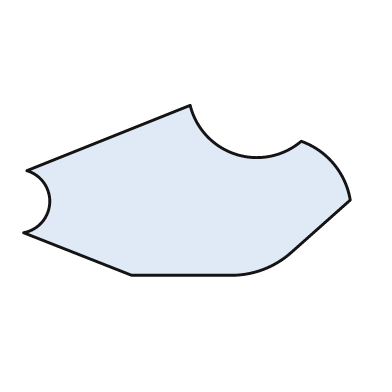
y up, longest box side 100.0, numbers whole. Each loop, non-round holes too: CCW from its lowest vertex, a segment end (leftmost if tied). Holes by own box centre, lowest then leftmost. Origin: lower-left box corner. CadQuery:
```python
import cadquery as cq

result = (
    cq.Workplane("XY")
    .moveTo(33.0, 0.0)
    .lineTo(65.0, 0.0)
    .threePointArc((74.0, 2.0), (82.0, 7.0))
    .lineTo(100.0, 23.0)
    .threePointArc((95.0, 34.0), (85.0, 41.0))
    .threePointArc((65.0, 37.0), (51.0, 52.0))
    .lineTo(1.0, 32.0)
    .threePointArc((8.0, 22.0), (0.0, 13.0))
    .close()
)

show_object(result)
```